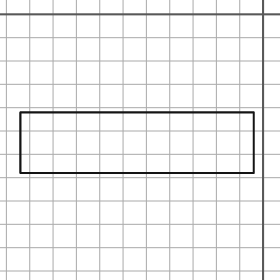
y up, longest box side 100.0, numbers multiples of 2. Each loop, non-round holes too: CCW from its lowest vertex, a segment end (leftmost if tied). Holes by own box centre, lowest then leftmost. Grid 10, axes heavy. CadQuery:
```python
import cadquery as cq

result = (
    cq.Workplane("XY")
    .moveTo(-104.0, -68.0)
    .lineTo(-4.0, -68.0)
    .lineTo(-4.0, -42.0)
    .lineTo(-104.0, -42.0)
    .close()
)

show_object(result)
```